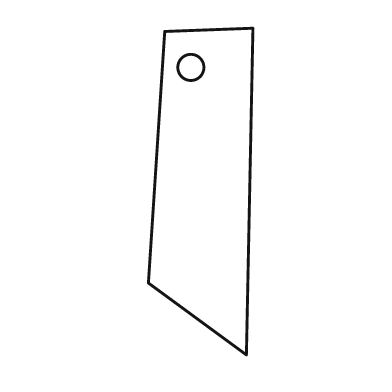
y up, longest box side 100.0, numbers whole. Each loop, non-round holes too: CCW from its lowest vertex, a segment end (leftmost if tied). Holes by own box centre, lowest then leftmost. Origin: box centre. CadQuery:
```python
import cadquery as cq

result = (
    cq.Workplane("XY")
    .moveTo(14.0, -50.0)
    .lineTo(16.0, 50.0)
    .lineTo(-11.0, 49.0)
    .lineTo(-16.0, -28.0)
    .close()
    .moveTo(-3.0, 38.0)
    .circle(4.0)
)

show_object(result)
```